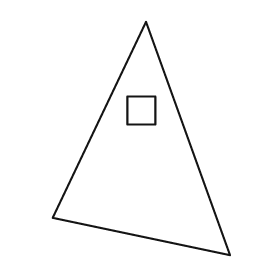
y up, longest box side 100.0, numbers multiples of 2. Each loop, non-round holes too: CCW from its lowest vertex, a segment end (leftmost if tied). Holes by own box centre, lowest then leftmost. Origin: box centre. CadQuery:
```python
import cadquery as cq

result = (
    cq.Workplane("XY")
    .moveTo(38.0, -50.0)
    .lineTo(2.0, 50.0)
    .lineTo(-38.0, -34.0)
    .close()
    .moveTo(-6.0, 6.0)
    .lineTo(6.0, 6.0)
    .lineTo(6.0, 18.0)
    .lineTo(-6.0, 18.0)
    .close()
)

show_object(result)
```